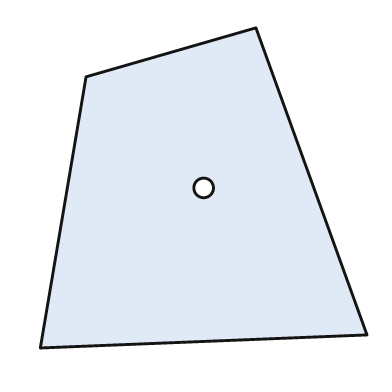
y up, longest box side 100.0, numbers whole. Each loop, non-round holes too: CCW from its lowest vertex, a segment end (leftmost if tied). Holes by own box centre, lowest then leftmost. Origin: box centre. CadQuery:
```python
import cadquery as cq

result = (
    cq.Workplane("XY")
    .moveTo(-50.0, -49.0)
    .lineTo(50.0, -45.0)
    .lineTo(16.0, 49.0)
    .lineTo(-36.0, 34.0)
    .close()
    .moveTo(0.0, 0.0)
    .circle(3.0)
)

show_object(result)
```